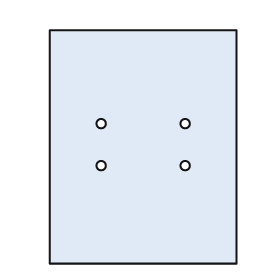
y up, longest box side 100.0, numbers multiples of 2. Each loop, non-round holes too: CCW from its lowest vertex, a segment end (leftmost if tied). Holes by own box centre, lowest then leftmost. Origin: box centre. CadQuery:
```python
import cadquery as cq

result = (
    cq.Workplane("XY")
    .moveTo(-40.0, -50.0)
    .lineTo(40.0, -50.0)
    .lineTo(40.0, 50.0)
    .lineTo(-40.0, 50.0)
    .close()
    .moveTo(-18.0, -8.0)
    .circle(2.0)
    .moveTo(18.0, -8.0)
    .circle(2.0)
    .moveTo(-18.0, 10.0)
    .circle(2.0)
    .moveTo(18.0, 10.0)
    .circle(2.0)
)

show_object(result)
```